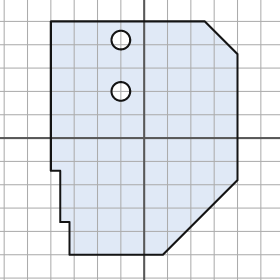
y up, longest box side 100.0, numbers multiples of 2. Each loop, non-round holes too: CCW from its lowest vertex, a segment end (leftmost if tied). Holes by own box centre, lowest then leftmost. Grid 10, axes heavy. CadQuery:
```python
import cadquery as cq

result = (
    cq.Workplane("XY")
    .moveTo(-32.0, -50.0)
    .lineTo(8.0, -50.0)
    .lineTo(40.0, -18.0)
    .lineTo(40.0, 36.0)
    .lineTo(26.0, 50.0)
    .lineTo(-40.0, 50.0)
    .lineTo(-40.0, -14.0)
    .lineTo(-36.0, -14.0)
    .lineTo(-36.0, -36.0)
    .lineTo(-32.0, -36.0)
    .close()
    .moveTo(-10.0, 20.0)
    .circle(4.0)
    .moveTo(-10.0, 42.0)
    .circle(4.0)
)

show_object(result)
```